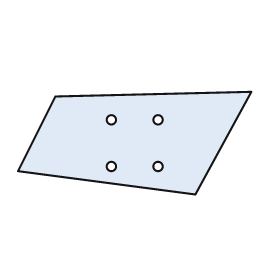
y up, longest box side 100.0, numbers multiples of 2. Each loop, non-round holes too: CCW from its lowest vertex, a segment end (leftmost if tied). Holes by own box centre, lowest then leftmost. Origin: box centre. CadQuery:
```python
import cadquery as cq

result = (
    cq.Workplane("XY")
    .moveTo(26.0, -22.0)
    .lineTo(50.0, 22.0)
    .lineTo(-34.0, 20.0)
    .lineTo(-50.0, -12.0)
    .close()
    .moveTo(-10.0, -10.0)
    .circle(2.0)
    .moveTo(10.0, -10.0)
    .circle(2.0)
    .moveTo(-10.0, 10.0)
    .circle(2.0)
    .moveTo(10.0, 10.0)
    .circle(2.0)
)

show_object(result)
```